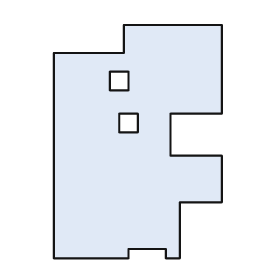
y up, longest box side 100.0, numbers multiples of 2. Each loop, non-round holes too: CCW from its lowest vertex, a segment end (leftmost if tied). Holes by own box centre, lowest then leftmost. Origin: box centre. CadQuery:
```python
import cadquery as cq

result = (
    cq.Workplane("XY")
    .moveTo(-36.0, -50.0)
    .lineTo(-4.0, -50.0)
    .lineTo(-4.0, -46.0)
    .lineTo(12.0, -46.0)
    .lineTo(12.0, -50.0)
    .lineTo(18.0, -50.0)
    .lineTo(18.0, -26.0)
    .lineTo(36.0, -26.0)
    .lineTo(36.0, -6.0)
    .lineTo(14.0, -6.0)
    .lineTo(14.0, 12.0)
    .lineTo(36.0, 12.0)
    .lineTo(36.0, 50.0)
    .lineTo(-6.0, 50.0)
    .lineTo(-6.0, 38.0)
    .lineTo(-36.0, 38.0)
    .close()
    .moveTo(-8.0, 4.0)
    .lineTo(0.0, 4.0)
    .lineTo(0.0, 12.0)
    .lineTo(-8.0, 12.0)
    .close()
    .moveTo(-12.0, 22.0)
    .lineTo(-4.0, 22.0)
    .lineTo(-4.0, 30.0)
    .lineTo(-12.0, 30.0)
    .close()
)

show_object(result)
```